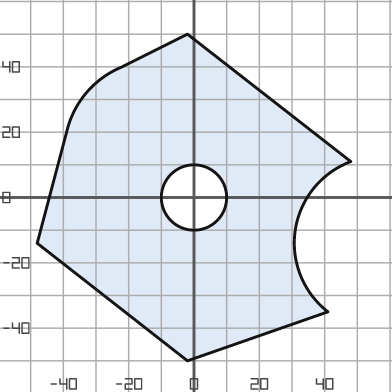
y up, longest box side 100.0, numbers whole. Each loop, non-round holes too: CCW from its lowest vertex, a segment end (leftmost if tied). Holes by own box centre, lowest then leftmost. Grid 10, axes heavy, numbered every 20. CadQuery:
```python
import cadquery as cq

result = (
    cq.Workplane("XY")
    .moveTo(-2.0, -50.0)
    .lineTo(41.0, -35.0)
    .threePointArc((31.0, -10.0), (48.0, 11.0))
    .lineTo(-2.0, 50.0)
    .lineTo(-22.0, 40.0)
    .threePointArc((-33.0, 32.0), (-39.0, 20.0))
    .lineTo(-48.0, -14.0)
    .close()
    .moveTo(0.0, 0.0)
    .circle(10.0)
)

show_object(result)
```